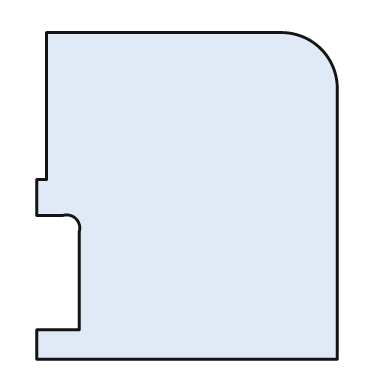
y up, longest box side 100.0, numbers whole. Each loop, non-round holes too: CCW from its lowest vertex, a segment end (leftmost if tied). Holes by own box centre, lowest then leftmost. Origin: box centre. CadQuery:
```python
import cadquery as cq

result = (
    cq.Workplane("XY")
    .moveTo(-46.0, -50.0)
    .lineTo(46.0, -50.0)
    .lineTo(46.0, 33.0)
    .threePointArc((41.0, 45.0), (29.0, 50.0))
    .lineTo(-43.0, 50.0)
    .lineTo(-43.0, 5.0)
    .lineTo(-46.0, 5.0)
    .lineTo(-46.0, -6.0)
    .lineTo(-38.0, -6.0)
    .threePointArc((-34.0, -7.0), (-33.0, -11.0))
    .lineTo(-33.0, -41.0)
    .lineTo(-46.0, -41.0)
    .close()
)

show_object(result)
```